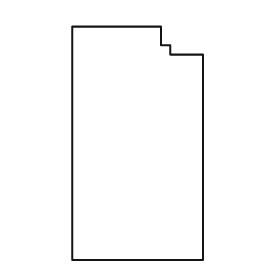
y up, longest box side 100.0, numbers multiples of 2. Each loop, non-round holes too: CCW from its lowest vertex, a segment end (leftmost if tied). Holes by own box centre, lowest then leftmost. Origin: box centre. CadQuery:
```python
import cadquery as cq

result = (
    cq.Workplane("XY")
    .moveTo(-28.0, -50.0)
    .lineTo(28.0, -50.0)
    .lineTo(28.0, 38.0)
    .lineTo(14.0, 38.0)
    .lineTo(14.0, 42.0)
    .lineTo(10.0, 42.0)
    .lineTo(10.0, 50.0)
    .lineTo(-28.0, 50.0)
    .close()
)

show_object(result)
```